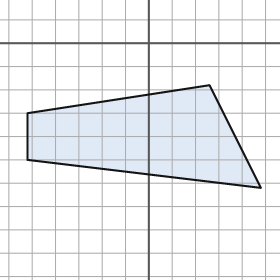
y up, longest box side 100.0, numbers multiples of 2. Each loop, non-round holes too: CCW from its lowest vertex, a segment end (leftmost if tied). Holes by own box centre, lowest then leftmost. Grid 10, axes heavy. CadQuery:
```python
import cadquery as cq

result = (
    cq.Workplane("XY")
    .moveTo(48.0, -62.0)
    .lineTo(26.0, -18.0)
    .lineTo(-52.0, -30.0)
    .lineTo(-52.0, -50.0)
    .close()
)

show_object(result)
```